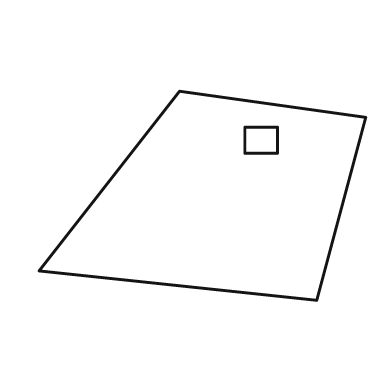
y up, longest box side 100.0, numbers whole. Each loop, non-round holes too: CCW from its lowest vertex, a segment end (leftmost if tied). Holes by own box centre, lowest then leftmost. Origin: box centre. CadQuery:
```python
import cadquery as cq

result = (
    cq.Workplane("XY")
    .moveTo(35.0, -32.0)
    .lineTo(50.0, 24.0)
    .lineTo(-7.0, 32.0)
    .lineTo(-50.0, -23.0)
    .close()
    .moveTo(13.0, 13.0)
    .lineTo(23.0, 13.0)
    .lineTo(23.0, 21.0)
    .lineTo(13.0, 21.0)
    .close()
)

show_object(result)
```